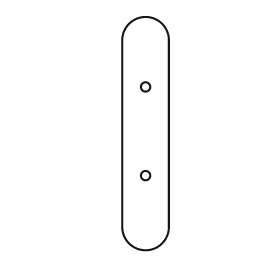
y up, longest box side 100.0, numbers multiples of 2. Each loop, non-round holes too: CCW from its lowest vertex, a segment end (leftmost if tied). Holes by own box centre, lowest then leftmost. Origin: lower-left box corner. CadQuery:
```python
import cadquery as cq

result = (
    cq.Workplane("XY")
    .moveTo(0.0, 10.0)
    .threePointArc((10.0, 0.0), (20.0, 10.0))
    .lineTo(20.0, 90.0)
    .threePointArc((10.0, 100.0), (0.0, 90.0))
    .close()
    .moveTo(10.0, 32.0)
    .circle(2.0)
    .moveTo(10.0, 70.0)
    .circle(2.0)
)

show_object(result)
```